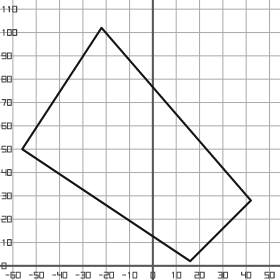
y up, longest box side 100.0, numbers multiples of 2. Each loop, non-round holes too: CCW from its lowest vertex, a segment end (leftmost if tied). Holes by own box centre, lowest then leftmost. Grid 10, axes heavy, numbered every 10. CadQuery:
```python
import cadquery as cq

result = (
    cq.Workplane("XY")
    .moveTo(16.0, 2.0)
    .lineTo(42.0, 28.0)
    .lineTo(-22.0, 102.0)
    .lineTo(-56.0, 50.0)
    .close()
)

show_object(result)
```